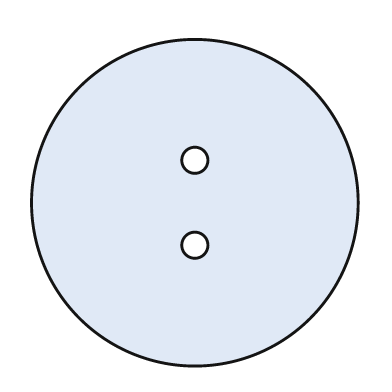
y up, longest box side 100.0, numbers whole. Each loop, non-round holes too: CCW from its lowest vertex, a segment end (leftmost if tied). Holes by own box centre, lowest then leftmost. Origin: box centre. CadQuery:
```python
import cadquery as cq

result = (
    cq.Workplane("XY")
    .moveTo(0.0, 0.0)
    .circle(50.0)
    .moveTo(0.0, -13.0)
    .circle(4.0)
    .moveTo(0.0, 13.0)
    .circle(4.0)
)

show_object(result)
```